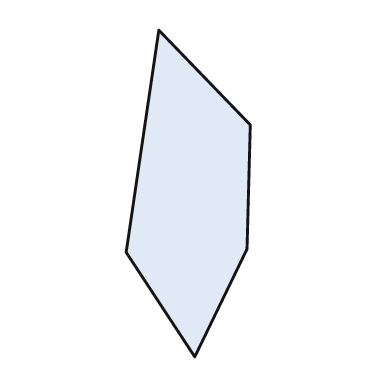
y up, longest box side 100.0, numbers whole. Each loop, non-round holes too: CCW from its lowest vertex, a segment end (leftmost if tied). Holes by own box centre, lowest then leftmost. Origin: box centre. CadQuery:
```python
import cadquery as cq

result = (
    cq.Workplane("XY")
    .moveTo(2.0, -50.0)
    .lineTo(18.0, -17.0)
    .lineTo(19.0, 21.0)
    .lineTo(-9.0, 50.0)
    .lineTo(-19.0, -18.0)
    .close()
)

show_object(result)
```